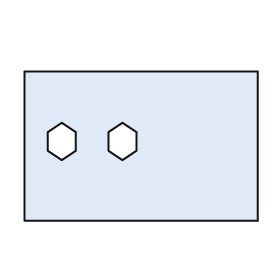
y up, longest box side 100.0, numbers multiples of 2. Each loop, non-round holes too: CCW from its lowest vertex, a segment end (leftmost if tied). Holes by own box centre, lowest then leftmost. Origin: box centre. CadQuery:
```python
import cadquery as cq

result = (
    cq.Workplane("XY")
    .moveTo(-50.0, -32.0)
    .lineTo(50.0, -32.0)
    .lineTo(50.0, 32.0)
    .lineTo(-50.0, 32.0)
    .close()
    .moveTo(-34.0, -6.0)
    .lineTo(-28.0, -2.0)
    .lineTo(-28.0, 6.0)
    .lineTo(-34.0, 10.0)
    .lineTo(-40.0, 6.0)
    .lineTo(-40.0, -2.0)
    .close()
    .moveTo(-8.0, -6.0)
    .lineTo(-2.0, -2.0)
    .lineTo(-2.0, 6.0)
    .lineTo(-8.0, 10.0)
    .lineTo(-14.0, 6.0)
    .lineTo(-14.0, -2.0)
    .close()
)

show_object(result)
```